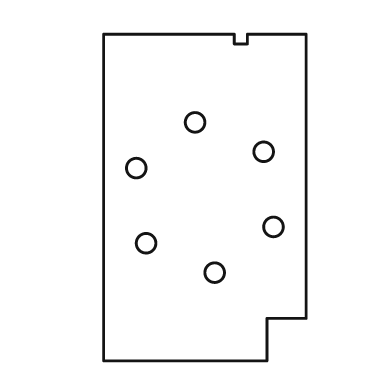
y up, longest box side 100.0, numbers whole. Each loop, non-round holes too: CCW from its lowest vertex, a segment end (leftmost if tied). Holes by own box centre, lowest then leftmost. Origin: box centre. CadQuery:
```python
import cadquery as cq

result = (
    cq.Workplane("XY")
    .moveTo(-31.0, -50.0)
    .lineTo(19.0, -50.0)
    .lineTo(19.0, -37.0)
    .lineTo(31.0, -37.0)
    .lineTo(31.0, 50.0)
    .lineTo(13.0, 50.0)
    .lineTo(13.0, 47.0)
    .lineTo(9.0, 47.0)
    .lineTo(9.0, 50.0)
    .lineTo(-31.0, 50.0)
    .close()
    .moveTo(3.0, -23.0)
    .circle(3.0)
    .moveTo(-18.0, -14.0)
    .circle(3.0)
    .moveTo(21.0, -9.0)
    .circle(3.0)
    .moveTo(-21.0, 9.0)
    .circle(3.0)
    .moveTo(18.0, 14.0)
    .circle(3.0)
    .moveTo(-3.0, 23.0)
    .circle(3.0)
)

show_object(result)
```